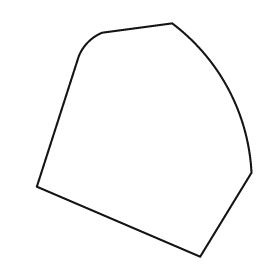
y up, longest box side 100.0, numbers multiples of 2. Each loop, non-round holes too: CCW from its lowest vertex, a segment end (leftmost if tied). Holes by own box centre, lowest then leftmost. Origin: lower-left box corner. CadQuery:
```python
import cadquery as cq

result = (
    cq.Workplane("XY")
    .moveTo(70.0, 0.0)
    .lineTo(92.0, 36.0)
    .threePointArc((82.0, 72.0), (58.0, 100.0))
    .lineTo(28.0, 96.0)
    .threePointArc((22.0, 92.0), (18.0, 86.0))
    .lineTo(0.0, 30.0)
    .close()
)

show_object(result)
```